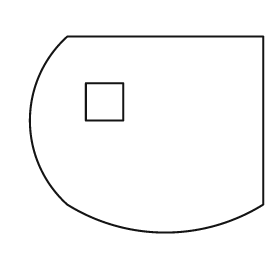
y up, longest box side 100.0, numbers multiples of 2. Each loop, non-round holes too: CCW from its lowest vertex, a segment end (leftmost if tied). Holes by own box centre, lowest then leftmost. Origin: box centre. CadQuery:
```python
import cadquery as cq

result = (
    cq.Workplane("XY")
    .moveTo(-34.0, -30.0)
    .threePointArc((8.0, -42.0), (50.0, -30.0))
    .lineTo(50.0, 42.0)
    .lineTo(-34.0, 42.0)
    .threePointArc((-50.0, 6.0), (-34.0, -30.0))
    .close()
    .moveTo(-26.0, 6.0)
    .lineTo(-10.0, 6.0)
    .lineTo(-10.0, 22.0)
    .lineTo(-26.0, 22.0)
    .close()
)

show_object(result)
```